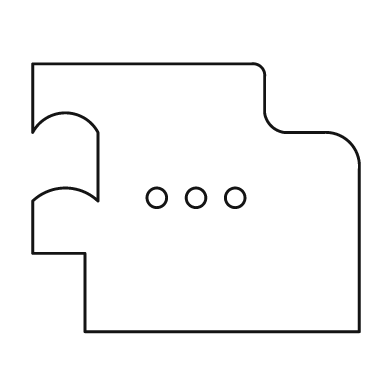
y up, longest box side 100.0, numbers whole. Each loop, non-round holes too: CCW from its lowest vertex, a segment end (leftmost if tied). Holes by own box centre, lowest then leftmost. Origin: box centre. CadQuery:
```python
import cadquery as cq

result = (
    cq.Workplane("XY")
    .moveTo(-34.0, -41.0)
    .lineTo(50.0, -41.0)
    .lineTo(50.0, 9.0)
    .threePointArc((47.0, 17.0), (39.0, 20.0))
    .lineTo(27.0, 20.0)
    .threePointArc((23.0, 22.0), (21.0, 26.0))
    .lineTo(21.0, 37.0)
    .threePointArc((20.0, 40.0), (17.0, 41.0))
    .lineTo(-50.0, 41.0)
    .lineTo(-50.0, 20.0)
    .threePointArc((-40.0, 26.0), (-30.0, 20.0))
    .lineTo(-30.0, -1.0)
    .threePointArc((-40.0, 3.0), (-50.0, -1.0))
    .lineTo(-50.0, -17.0)
    .lineTo(-34.0, -17.0)
    .close()
    .moveTo(-12.0, 0.0)
    .circle(3.0)
    .moveTo(0.0, 0.0)
    .circle(3.0)
    .moveTo(12.0, 0.0)
    .circle(3.0)
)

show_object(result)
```